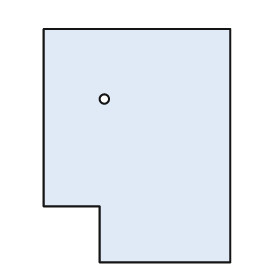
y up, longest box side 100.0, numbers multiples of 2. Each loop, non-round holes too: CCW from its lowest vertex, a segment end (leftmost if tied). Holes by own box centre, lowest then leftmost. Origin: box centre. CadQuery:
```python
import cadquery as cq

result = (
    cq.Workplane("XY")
    .moveTo(-16.0, -50.0)
    .lineTo(40.0, -50.0)
    .lineTo(40.0, 50.0)
    .lineTo(-40.0, 50.0)
    .lineTo(-40.0, -26.0)
    .lineTo(-16.0, -26.0)
    .close()
    .moveTo(-14.0, 20.0)
    .circle(2.0)
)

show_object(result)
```